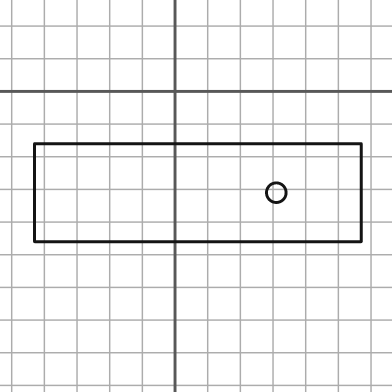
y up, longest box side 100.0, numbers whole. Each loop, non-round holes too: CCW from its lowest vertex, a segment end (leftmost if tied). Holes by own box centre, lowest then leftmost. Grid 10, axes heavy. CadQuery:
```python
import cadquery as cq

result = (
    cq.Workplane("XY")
    .moveTo(-43.0, -46.0)
    .lineTo(57.0, -46.0)
    .lineTo(57.0, -16.0)
    .lineTo(-43.0, -16.0)
    .close()
    .moveTo(31.0, -31.0)
    .circle(3.0)
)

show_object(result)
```